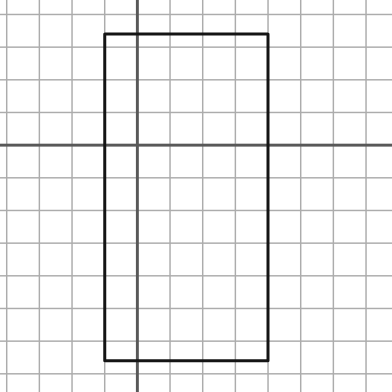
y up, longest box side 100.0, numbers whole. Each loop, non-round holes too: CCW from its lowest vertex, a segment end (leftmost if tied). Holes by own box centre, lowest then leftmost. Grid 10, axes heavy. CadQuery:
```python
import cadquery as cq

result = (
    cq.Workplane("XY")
    .moveTo(-10.0, -66.0)
    .lineTo(40.0, -66.0)
    .lineTo(40.0, 34.0)
    .lineTo(-10.0, 34.0)
    .close()
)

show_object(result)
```